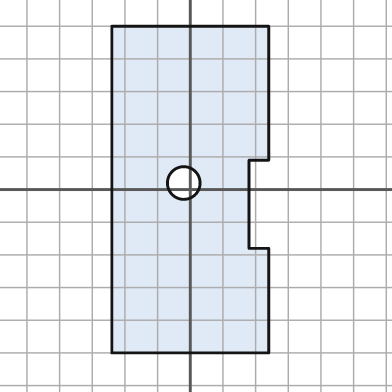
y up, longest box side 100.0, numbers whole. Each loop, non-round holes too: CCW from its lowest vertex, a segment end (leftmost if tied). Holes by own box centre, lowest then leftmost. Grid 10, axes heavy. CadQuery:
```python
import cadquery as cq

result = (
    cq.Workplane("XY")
    .moveTo(-24.0, -50.0)
    .lineTo(24.0, -50.0)
    .lineTo(24.0, -18.0)
    .lineTo(18.0, -18.0)
    .lineTo(18.0, 9.0)
    .lineTo(24.0, 9.0)
    .lineTo(24.0, 50.0)
    .lineTo(-24.0, 50.0)
    .close()
    .moveTo(-2.0, 2.0)
    .circle(5.0)
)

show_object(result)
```